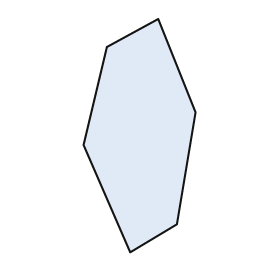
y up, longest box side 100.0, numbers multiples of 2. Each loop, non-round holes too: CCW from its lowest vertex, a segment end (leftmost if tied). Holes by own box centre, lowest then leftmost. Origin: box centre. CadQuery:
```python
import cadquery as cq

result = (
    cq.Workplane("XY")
    .moveTo(-4.0, -50.0)
    .lineTo(16.0, -38.0)
    .lineTo(24.0, 10.0)
    .lineTo(8.0, 50.0)
    .lineTo(-14.0, 38.0)
    .lineTo(-24.0, -4.0)
    .close()
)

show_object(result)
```